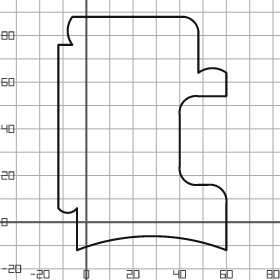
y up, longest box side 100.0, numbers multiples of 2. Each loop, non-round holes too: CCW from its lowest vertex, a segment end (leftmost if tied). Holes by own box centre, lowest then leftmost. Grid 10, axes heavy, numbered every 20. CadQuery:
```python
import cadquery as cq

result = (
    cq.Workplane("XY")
    .moveTo(-4.0, -12.0)
    .threePointArc((28.0, -6.0), (60.0, -12.0))
    .lineTo(60.0, 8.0)
    .threePointArc((58.0, 14.0), (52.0, 16.0))
    .lineTo(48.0, 16.0)
    .threePointArc((42.0, 18.0), (40.0, 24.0))
    .lineTo(40.0, 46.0)
    .threePointArc((42.0, 52.0), (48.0, 54.0))
    .lineTo(60.0, 54.0)
    .lineTo(60.0, 64.0)
    .threePointArc((54.0, 66.0), (48.0, 64.0))
    .lineTo(48.0, 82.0)
    .threePointArc((46.0, 86.0), (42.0, 88.0))
    .lineTo(-6.0, 88.0)
    .threePointArc((-8.0, 82.0), (-6.0, 76.0))
    .lineTo(-12.0, 76.0)
    .lineTo(-12.0, 6.0)
    .threePointArc((-8.0, 4.0), (-4.0, 6.0))
    .close()
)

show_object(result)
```